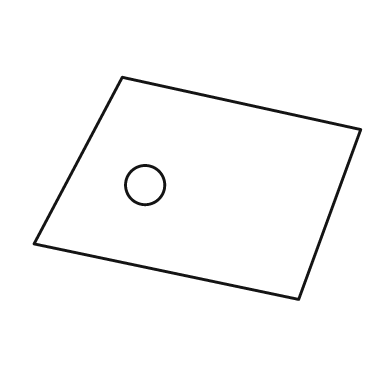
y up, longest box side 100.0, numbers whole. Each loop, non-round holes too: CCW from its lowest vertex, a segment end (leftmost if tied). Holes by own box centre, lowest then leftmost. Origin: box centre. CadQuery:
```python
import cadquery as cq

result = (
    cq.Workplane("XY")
    .moveTo(31.0, -34.0)
    .lineTo(50.0, 18.0)
    .lineTo(-23.0, 34.0)
    .lineTo(-50.0, -17.0)
    .close()
    .moveTo(-16.0, 1.0)
    .circle(6.0)
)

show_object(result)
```